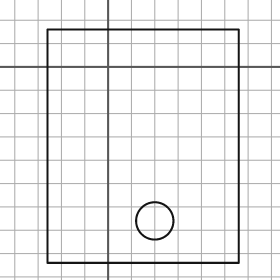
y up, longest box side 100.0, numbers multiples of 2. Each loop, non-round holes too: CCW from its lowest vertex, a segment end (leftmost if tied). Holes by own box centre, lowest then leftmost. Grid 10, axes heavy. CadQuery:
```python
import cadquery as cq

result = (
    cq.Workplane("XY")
    .moveTo(-26.0, -84.0)
    .lineTo(56.0, -84.0)
    .lineTo(56.0, 16.0)
    .lineTo(-26.0, 16.0)
    .close()
    .moveTo(20.0, -66.0)
    .circle(8.0)
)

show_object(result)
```